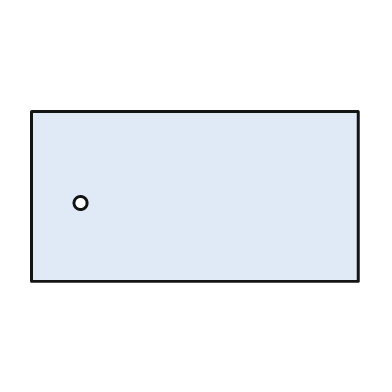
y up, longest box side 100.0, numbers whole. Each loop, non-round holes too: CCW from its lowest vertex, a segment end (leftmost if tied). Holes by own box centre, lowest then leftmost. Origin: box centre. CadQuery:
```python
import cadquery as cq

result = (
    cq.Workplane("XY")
    .moveTo(-50.0, -26.0)
    .lineTo(50.0, -26.0)
    .lineTo(50.0, 26.0)
    .lineTo(-50.0, 26.0)
    .close()
    .moveTo(-35.0, -2.0)
    .circle(2.0)
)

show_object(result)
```